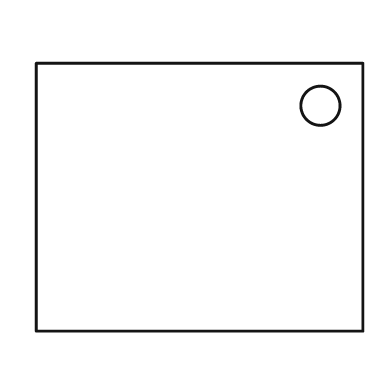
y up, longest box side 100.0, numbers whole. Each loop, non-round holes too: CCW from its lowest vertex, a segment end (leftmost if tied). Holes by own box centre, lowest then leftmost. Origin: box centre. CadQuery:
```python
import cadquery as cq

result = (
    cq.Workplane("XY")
    .moveTo(-50.0, -41.0)
    .lineTo(50.0, -41.0)
    .lineTo(50.0, 41.0)
    .lineTo(-50.0, 41.0)
    .close()
    .moveTo(37.0, 28.0)
    .circle(6.0)
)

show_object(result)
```